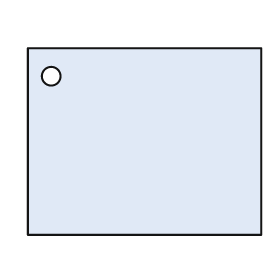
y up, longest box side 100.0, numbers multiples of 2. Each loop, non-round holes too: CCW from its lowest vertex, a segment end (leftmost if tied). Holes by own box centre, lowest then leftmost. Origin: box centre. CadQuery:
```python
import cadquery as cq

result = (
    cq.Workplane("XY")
    .moveTo(-50.0, -40.0)
    .lineTo(50.0, -40.0)
    .lineTo(50.0, 40.0)
    .lineTo(-50.0, 40.0)
    .close()
    .moveTo(-40.0, 28.0)
    .circle(4.0)
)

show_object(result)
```